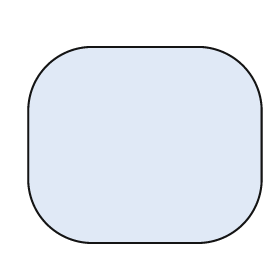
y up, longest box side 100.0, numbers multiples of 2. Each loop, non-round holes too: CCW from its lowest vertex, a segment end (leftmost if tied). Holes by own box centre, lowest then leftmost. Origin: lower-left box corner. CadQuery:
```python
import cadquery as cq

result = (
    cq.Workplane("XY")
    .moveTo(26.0, 0.0)
    .lineTo(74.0, 0.0)
    .threePointArc((92.0, 8.0), (100.0, 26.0))
    .lineTo(100.0, 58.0)
    .threePointArc((92.0, 76.0), (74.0, 84.0))
    .lineTo(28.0, 84.0)
    .threePointArc((8.0, 76.0), (0.0, 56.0))
    .lineTo(0.0, 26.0)
    .threePointArc((8.0, 8.0), (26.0, 0.0))
    .close()
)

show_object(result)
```